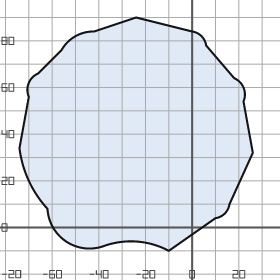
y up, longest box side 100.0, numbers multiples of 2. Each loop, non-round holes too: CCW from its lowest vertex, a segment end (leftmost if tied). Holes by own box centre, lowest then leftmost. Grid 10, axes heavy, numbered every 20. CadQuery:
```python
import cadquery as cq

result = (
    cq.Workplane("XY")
    .moveTo(-10.0, -10.0)
    .lineTo(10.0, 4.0)
    .threePointArc((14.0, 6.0), (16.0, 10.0))
    .lineTo(26.0, 32.0)
    .lineTo(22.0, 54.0)
    .threePointArc((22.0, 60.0), (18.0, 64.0))
    .lineTo(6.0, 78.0)
    .threePointArc((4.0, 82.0), (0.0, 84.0))
    .lineTo(-24.0, 90.0)
    .lineTo(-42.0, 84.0)
    .threePointArc((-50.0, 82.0), (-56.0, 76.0))
    .lineTo(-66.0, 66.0)
    .threePointArc((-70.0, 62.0), (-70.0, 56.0))
    .lineTo(-74.0, 34.0)
    .threePointArc((-70.0, 20.0), (-62.0, 8.0))
    .threePointArc((-54.0, -6.0), (-38.0, -8.0))
    .threePointArc((-24.0, -6.0), (-10.0, -10.0))
    .close()
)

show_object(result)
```